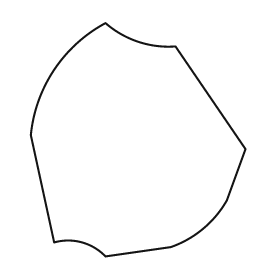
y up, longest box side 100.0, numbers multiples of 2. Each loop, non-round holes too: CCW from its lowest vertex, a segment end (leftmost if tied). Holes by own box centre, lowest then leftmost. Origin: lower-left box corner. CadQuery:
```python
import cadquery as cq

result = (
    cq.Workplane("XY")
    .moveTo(32.0, 0.0)
    .lineTo(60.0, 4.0)
    .threePointArc((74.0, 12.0), (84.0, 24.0))
    .lineTo(92.0, 46.0)
    .lineTo(62.0, 90.0)
    .threePointArc((46.0, 92.0), (32.0, 100.0))
    .threePointArc((10.0, 80.0), (0.0, 52.0))
    .lineTo(10.0, 6.0)
    .threePointArc((22.0, 6.0), (32.0, 0.0))
    .close()
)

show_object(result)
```